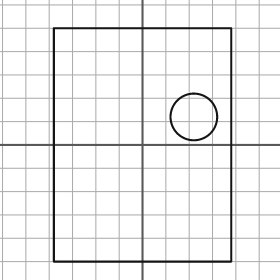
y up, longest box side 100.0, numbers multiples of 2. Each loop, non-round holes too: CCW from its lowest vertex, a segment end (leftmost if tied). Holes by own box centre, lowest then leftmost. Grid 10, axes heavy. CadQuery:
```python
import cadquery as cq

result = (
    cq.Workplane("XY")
    .moveTo(-38.0, -50.0)
    .lineTo(38.0, -50.0)
    .lineTo(38.0, 50.0)
    .lineTo(-38.0, 50.0)
    .close()
    .moveTo(22.0, 12.0)
    .circle(10.0)
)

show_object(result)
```